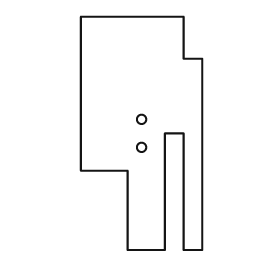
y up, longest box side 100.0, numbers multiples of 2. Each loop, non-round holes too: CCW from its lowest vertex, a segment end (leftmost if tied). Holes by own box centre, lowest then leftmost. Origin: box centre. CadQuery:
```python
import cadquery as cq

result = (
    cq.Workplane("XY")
    .moveTo(-6.0, -50.0)
    .lineTo(10.0, -50.0)
    .lineTo(10.0, 0.0)
    .lineTo(18.0, 0.0)
    .lineTo(18.0, -50.0)
    .lineTo(26.0, -50.0)
    .lineTo(26.0, 32.0)
    .lineTo(18.0, 32.0)
    .lineTo(18.0, 50.0)
    .lineTo(-26.0, 50.0)
    .lineTo(-26.0, -16.0)
    .lineTo(-6.0, -16.0)
    .close()
    .moveTo(0.0, -6.0)
    .circle(2.0)
    .moveTo(0.0, 6.0)
    .circle(2.0)
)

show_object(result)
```